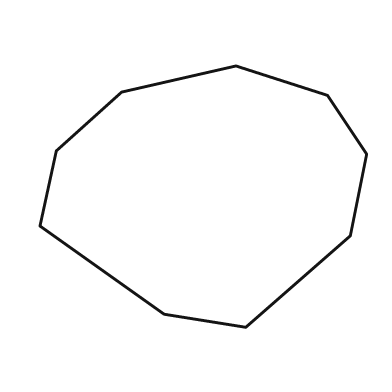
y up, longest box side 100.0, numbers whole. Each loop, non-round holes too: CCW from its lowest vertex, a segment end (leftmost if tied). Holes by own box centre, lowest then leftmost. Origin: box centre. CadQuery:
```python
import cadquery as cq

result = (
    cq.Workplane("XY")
    .moveTo(13.0, -40.0)
    .lineTo(45.0, -12.0)
    .lineTo(50.0, 13.0)
    .lineTo(38.0, 31.0)
    .lineTo(10.0, 40.0)
    .lineTo(-25.0, 32.0)
    .lineTo(-45.0, 14.0)
    .lineTo(-50.0, -9.0)
    .lineTo(-12.0, -36.0)
    .close()
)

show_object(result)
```